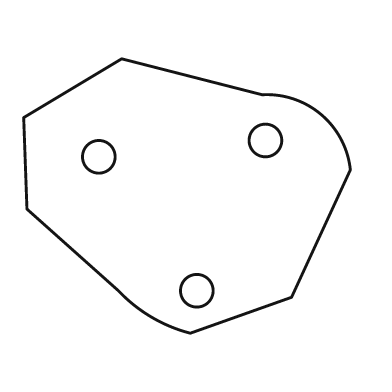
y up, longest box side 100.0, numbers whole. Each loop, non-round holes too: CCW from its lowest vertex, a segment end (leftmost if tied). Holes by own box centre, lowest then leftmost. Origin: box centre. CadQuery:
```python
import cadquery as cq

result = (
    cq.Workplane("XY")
    .moveTo(1.0, -42.0)
    .lineTo(32.0, -31.0)
    .lineTo(50.0, 8.0)
    .threePointArc((41.0, 25.0), (23.0, 31.0))
    .lineTo(-20.0, 42.0)
    .lineTo(-50.0, 24.0)
    .lineTo(-49.0, -4.0)
    .lineTo(-21.0, -29.0)
    .threePointArc((-11.0, -37.0), (1.0, -42.0))
    .close()
    .moveTo(3.0, -29.0)
    .circle(5.0)
    .moveTo(-27.0, 12.0)
    .circle(5.0)
    .moveTo(24.0, 17.0)
    .circle(5.0)
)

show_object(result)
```